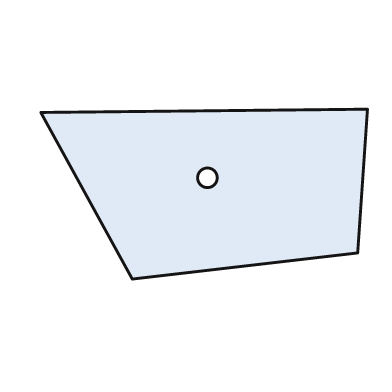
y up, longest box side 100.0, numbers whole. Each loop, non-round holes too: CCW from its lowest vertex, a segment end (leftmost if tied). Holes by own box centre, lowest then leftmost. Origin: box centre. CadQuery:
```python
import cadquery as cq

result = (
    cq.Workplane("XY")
    .moveTo(-22.0, -26.0)
    .lineTo(47.0, -18.0)
    .lineTo(50.0, 26.0)
    .lineTo(-50.0, 25.0)
    .close()
    .moveTo(1.0, 5.0)
    .circle(3.0)
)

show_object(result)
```